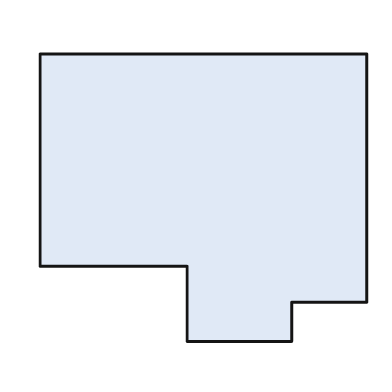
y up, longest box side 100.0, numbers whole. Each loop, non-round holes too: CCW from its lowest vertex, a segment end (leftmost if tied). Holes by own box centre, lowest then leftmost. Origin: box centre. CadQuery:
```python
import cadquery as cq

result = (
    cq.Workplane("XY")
    .moveTo(-5.0, -44.0)
    .lineTo(27.0, -44.0)
    .lineTo(27.0, -32.0)
    .lineTo(50.0, -32.0)
    .lineTo(50.0, 44.0)
    .lineTo(-50.0, 44.0)
    .lineTo(-50.0, -21.0)
    .lineTo(-5.0, -21.0)
    .close()
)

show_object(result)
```